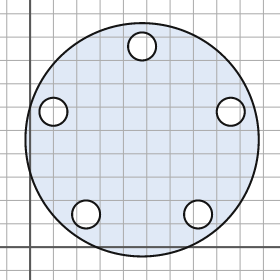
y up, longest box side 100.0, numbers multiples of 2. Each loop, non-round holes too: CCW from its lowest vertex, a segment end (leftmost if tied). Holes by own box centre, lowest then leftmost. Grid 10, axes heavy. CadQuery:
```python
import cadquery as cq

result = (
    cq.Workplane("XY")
    .moveTo(48.0, 46.0)
    .circle(50.0)
    .moveTo(24.0, 14.0)
    .circle(6.0)
    .moveTo(72.0, 14.0)
    .circle(6.0)
    .moveTo(10.0, 58.0)
    .circle(6.0)
    .moveTo(86.0, 58.0)
    .circle(6.0)
    .moveTo(48.0, 86.0)
    .circle(6.0)
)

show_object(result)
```